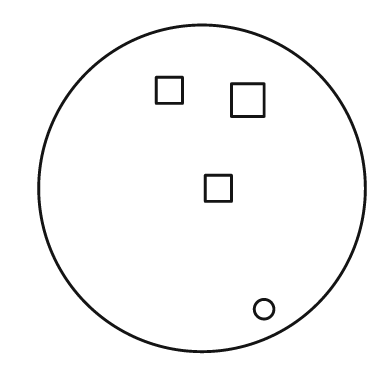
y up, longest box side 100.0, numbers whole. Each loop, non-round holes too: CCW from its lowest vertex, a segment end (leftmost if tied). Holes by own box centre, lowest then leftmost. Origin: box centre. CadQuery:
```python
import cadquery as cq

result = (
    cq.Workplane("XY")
    .moveTo(0.0, 0.0)
    .circle(50.0)
    .moveTo(19.0, -37.0)
    .circle(3.0)
    .moveTo(1.0, -4.0)
    .lineTo(9.0, -4.0)
    .lineTo(9.0, 4.0)
    .lineTo(1.0, 4.0)
    .close()
    .moveTo(9.0, 22.0)
    .lineTo(19.0, 22.0)
    .lineTo(19.0, 32.0)
    .lineTo(9.0, 32.0)
    .close()
    .moveTo(-14.0, 26.0)
    .lineTo(-6.0, 26.0)
    .lineTo(-6.0, 34.0)
    .lineTo(-14.0, 34.0)
    .close()
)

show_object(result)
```